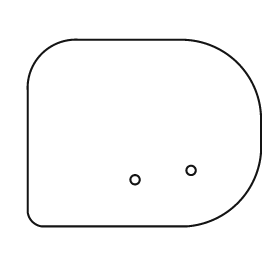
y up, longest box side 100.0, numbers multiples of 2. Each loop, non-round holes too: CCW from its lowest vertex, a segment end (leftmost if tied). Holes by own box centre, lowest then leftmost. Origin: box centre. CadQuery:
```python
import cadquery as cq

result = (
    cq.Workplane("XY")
    .moveTo(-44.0, -40.0)
    .lineTo(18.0, -40.0)
    .threePointArc((40.0, -30.0), (50.0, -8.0))
    .lineTo(50.0, 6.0)
    .threePointArc((40.0, 30.0), (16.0, 40.0))
    .lineTo(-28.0, 40.0)
    .threePointArc((-44.0, 34.0), (-50.0, 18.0))
    .lineTo(-50.0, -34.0)
    .threePointArc((-48.0, -38.0), (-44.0, -40.0))
    .close()
    .moveTo(-4.0, -20.0)
    .circle(2.0)
    .moveTo(20.0, -16.0)
    .circle(2.0)
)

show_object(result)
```